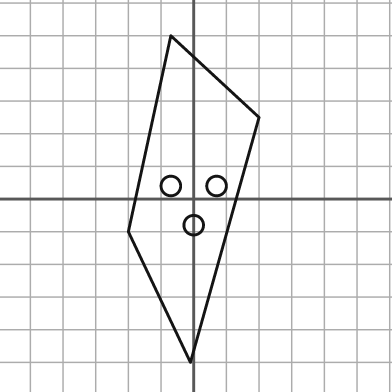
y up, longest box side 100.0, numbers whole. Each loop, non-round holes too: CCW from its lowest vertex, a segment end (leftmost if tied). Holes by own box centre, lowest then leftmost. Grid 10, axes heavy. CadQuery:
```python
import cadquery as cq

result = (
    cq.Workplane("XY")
    .moveTo(-1.0, -50.0)
    .lineTo(20.0, 25.0)
    .lineTo(-7.0, 50.0)
    .lineTo(-20.0, -10.0)
    .close()
    .moveTo(0.0, -8.0)
    .circle(3.0)
    .moveTo(-7.0, 4.0)
    .circle(3.0)
    .moveTo(7.0, 4.0)
    .circle(3.0)
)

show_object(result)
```